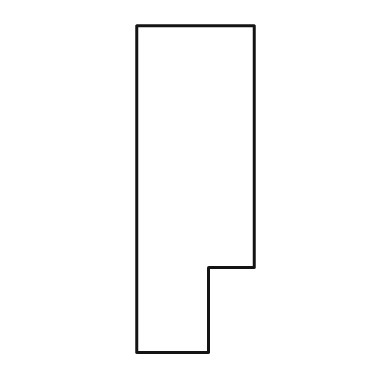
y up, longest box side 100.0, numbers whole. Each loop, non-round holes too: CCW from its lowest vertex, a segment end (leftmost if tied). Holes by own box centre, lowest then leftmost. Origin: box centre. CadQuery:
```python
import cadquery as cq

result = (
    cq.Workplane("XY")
    .moveTo(-18.0, -50.0)
    .lineTo(4.0, -50.0)
    .lineTo(4.0, -24.0)
    .lineTo(18.0, -24.0)
    .lineTo(18.0, 50.0)
    .lineTo(-18.0, 50.0)
    .close()
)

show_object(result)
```